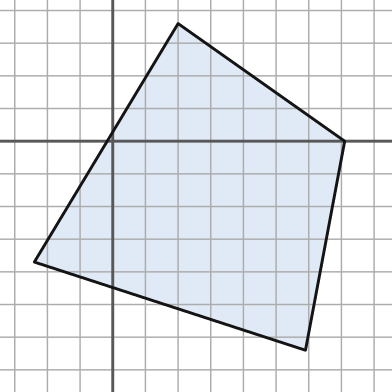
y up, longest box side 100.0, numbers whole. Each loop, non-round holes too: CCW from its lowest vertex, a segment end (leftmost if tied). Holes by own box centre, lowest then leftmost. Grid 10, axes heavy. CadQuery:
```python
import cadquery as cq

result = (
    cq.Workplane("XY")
    .moveTo(59.0, -64.0)
    .lineTo(71.0, 0.0)
    .lineTo(20.0, 36.0)
    .lineTo(-24.0, -37.0)
    .close()
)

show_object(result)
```